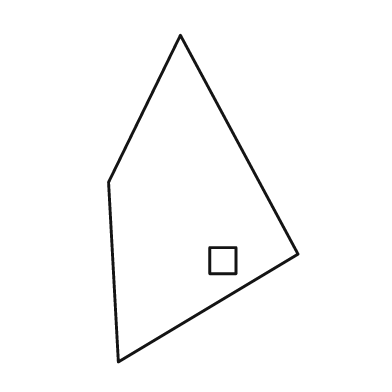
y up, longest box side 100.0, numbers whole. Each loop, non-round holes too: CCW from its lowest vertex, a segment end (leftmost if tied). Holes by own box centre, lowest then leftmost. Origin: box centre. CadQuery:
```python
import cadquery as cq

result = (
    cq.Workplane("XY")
    .moveTo(-26.0, -50.0)
    .lineTo(29.0, -17.0)
    .lineTo(-7.0, 50.0)
    .lineTo(-29.0, 5.0)
    .close()
    .moveTo(2.0, -23.0)
    .lineTo(10.0, -23.0)
    .lineTo(10.0, -15.0)
    .lineTo(2.0, -15.0)
    .close()
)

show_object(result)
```